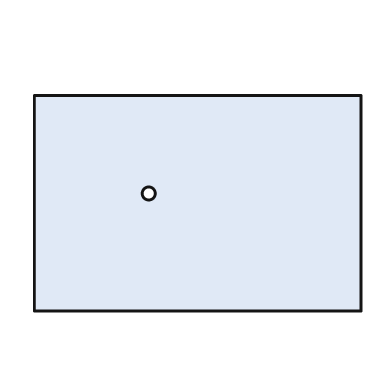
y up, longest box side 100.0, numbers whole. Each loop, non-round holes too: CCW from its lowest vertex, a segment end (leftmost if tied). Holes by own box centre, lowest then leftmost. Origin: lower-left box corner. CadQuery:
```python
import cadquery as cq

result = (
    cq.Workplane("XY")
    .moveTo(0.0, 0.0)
    .lineTo(100.0, 0.0)
    .lineTo(100.0, 66.0)
    .lineTo(0.0, 66.0)
    .close()
    .moveTo(35.0, 36.0)
    .circle(2.0)
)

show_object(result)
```